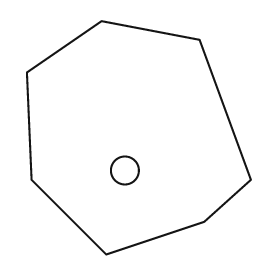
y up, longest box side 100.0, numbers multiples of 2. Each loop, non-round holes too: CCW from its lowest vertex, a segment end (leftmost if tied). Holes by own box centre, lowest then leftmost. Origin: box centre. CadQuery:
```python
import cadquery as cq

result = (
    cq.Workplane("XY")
    .moveTo(-14.0, -50.0)
    .lineTo(28.0, -36.0)
    .lineTo(48.0, -18.0)
    .lineTo(26.0, 42.0)
    .lineTo(-16.0, 50.0)
    .lineTo(-48.0, 28.0)
    .lineTo(-46.0, -18.0)
    .close()
    .moveTo(-6.0, -14.0)
    .circle(6.0)
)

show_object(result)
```